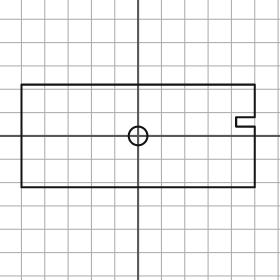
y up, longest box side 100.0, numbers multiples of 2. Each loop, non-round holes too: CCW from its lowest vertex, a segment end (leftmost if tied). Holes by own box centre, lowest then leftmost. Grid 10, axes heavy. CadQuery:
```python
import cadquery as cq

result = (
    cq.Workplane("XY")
    .moveTo(-50.0, -22.0)
    .lineTo(50.0, -22.0)
    .lineTo(50.0, 4.0)
    .lineTo(42.0, 4.0)
    .lineTo(42.0, 8.0)
    .lineTo(50.0, 8.0)
    .lineTo(50.0, 22.0)
    .lineTo(-50.0, 22.0)
    .close()
    .moveTo(0.0, 0.0)
    .circle(4.0)
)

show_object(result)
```